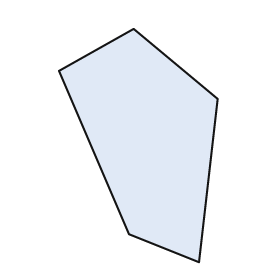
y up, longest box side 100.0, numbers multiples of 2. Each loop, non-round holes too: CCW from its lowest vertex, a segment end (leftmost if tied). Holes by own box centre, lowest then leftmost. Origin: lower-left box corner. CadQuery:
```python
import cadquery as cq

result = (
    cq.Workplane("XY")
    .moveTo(60.0, 0.0)
    .lineTo(68.0, 70.0)
    .lineTo(32.0, 100.0)
    .lineTo(0.0, 82.0)
    .lineTo(30.0, 12.0)
    .close()
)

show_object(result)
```